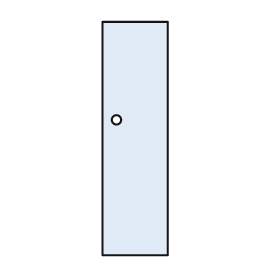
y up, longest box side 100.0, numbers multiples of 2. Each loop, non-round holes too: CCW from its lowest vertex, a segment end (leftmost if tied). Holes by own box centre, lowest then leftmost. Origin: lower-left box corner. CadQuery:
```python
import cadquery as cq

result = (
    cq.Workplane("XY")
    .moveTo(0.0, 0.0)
    .lineTo(28.0, 0.0)
    .lineTo(28.0, 100.0)
    .lineTo(0.0, 100.0)
    .close()
    .moveTo(6.0, 58.0)
    .circle(2.0)
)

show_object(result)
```